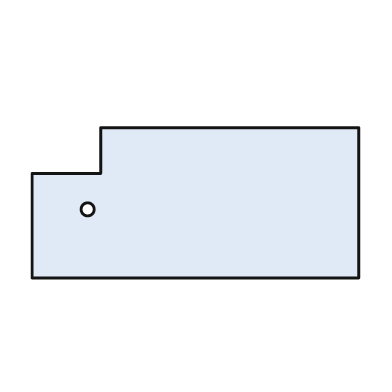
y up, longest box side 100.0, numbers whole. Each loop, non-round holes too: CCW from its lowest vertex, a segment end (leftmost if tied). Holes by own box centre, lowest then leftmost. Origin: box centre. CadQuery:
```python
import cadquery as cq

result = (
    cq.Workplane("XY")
    .moveTo(-50.0, -23.0)
    .lineTo(50.0, -23.0)
    .lineTo(50.0, 23.0)
    .lineTo(-29.0, 23.0)
    .lineTo(-29.0, 9.0)
    .lineTo(-50.0, 9.0)
    .close()
    .moveTo(-33.0, -2.0)
    .circle(2.0)
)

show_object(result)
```